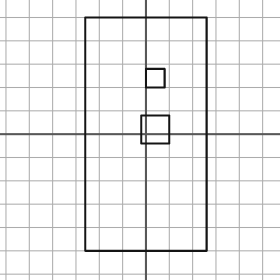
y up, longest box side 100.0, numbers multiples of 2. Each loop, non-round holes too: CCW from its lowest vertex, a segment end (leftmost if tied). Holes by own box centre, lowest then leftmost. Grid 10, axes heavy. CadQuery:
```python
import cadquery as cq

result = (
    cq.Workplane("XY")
    .moveTo(-26.0, -50.0)
    .lineTo(26.0, -50.0)
    .lineTo(26.0, 50.0)
    .lineTo(-26.0, 50.0)
    .close()
    .moveTo(-2.0, -4.0)
    .lineTo(10.0, -4.0)
    .lineTo(10.0, 8.0)
    .lineTo(-2.0, 8.0)
    .close()
    .moveTo(0.0, 20.0)
    .lineTo(8.0, 20.0)
    .lineTo(8.0, 28.0)
    .lineTo(0.0, 28.0)
    .close()
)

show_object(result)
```